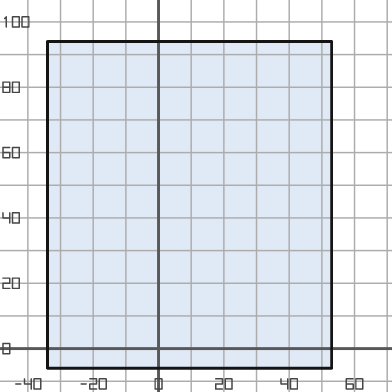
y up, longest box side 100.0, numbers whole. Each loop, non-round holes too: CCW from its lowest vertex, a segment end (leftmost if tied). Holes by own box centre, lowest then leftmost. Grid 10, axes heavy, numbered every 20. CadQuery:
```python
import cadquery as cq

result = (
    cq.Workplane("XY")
    .moveTo(-34.0, -6.0)
    .lineTo(53.0, -6.0)
    .lineTo(53.0, 94.0)
    .lineTo(-34.0, 94.0)
    .close()
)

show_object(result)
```